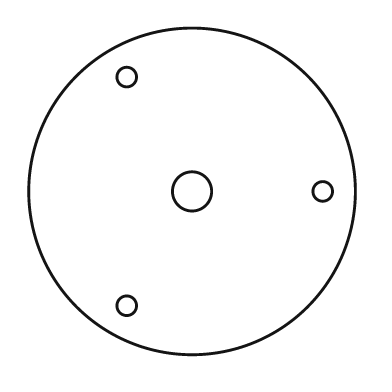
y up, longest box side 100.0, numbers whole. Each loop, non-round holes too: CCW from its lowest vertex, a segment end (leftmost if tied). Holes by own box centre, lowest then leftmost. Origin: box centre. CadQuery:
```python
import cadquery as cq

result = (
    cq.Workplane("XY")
    .moveTo(0.0, 0.0)
    .circle(50.0)
    .moveTo(-20.0, -35.0)
    .circle(3.0)
    .moveTo(0.0, 0.0)
    .circle(6.0)
    .moveTo(40.0, 0.0)
    .circle(3.0)
    .moveTo(-20.0, 35.0)
    .circle(3.0)
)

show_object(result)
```